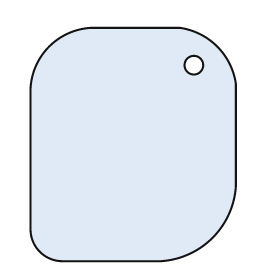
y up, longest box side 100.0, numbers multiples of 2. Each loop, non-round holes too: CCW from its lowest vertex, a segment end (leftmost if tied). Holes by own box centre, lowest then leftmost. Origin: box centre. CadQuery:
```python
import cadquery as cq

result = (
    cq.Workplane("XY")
    .moveTo(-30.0, -50.0)
    .lineTo(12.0, -50.0)
    .threePointArc((34.0, -40.0), (44.0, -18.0))
    .lineTo(44.0, 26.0)
    .threePointArc((36.0, 42.0), (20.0, 50.0))
    .lineTo(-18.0, 50.0)
    .threePointArc((-36.0, 42.0), (-44.0, 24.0))
    .lineTo(-44.0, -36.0)
    .threePointArc((-40.0, -46.0), (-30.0, -50.0))
    .close()
    .moveTo(26.0, 34.0)
    .circle(4.0)
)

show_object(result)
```